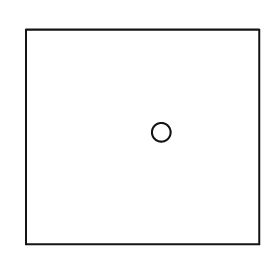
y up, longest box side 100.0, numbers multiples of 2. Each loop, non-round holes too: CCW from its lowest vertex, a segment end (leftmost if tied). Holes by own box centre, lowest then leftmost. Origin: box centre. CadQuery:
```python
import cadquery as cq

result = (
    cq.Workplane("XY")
    .moveTo(-50.0, -46.0)
    .lineTo(50.0, -46.0)
    .lineTo(50.0, 46.0)
    .lineTo(-50.0, 46.0)
    .close()
    .moveTo(8.0, 2.0)
    .circle(4.0)
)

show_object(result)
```